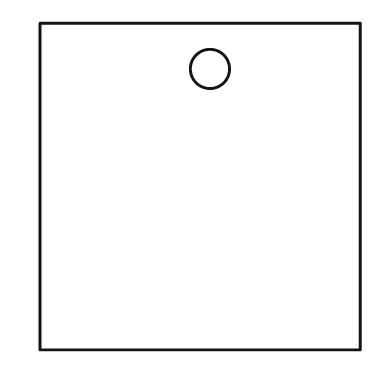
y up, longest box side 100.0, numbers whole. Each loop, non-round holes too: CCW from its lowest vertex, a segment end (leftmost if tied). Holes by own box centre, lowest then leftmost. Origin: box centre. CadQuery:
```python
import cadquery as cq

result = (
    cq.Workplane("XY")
    .moveTo(-49.0, -50.0)
    .lineTo(49.0, -50.0)
    .lineTo(49.0, 50.0)
    .lineTo(-49.0, 50.0)
    .close()
    .moveTo(3.0, 36.0)
    .circle(6.0)
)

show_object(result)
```